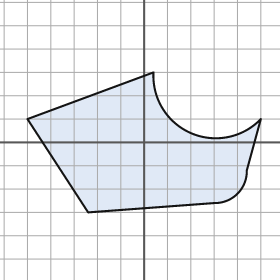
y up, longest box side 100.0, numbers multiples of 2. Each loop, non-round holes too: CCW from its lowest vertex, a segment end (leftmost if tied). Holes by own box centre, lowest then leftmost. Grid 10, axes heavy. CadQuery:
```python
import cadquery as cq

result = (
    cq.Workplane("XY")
    .moveTo(-24.0, -30.0)
    .lineTo(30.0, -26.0)
    .threePointArc((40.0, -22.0), (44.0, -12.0))
    .lineTo(50.0, 10.0)
    .threePointArc((20.0, 4.0), (4.0, 30.0))
    .lineTo(-50.0, 10.0)
    .close()
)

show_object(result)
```